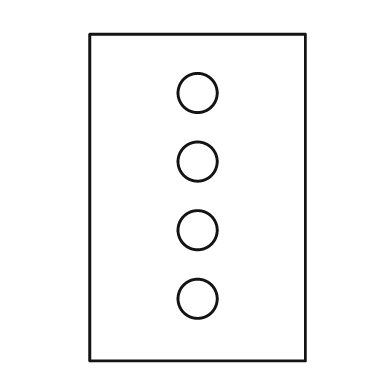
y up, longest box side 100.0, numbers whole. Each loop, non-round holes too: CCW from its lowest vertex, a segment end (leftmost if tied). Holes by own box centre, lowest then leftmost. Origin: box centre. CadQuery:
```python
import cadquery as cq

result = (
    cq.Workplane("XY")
    .moveTo(-33.0, -50.0)
    .lineTo(33.0, -50.0)
    .lineTo(33.0, 50.0)
    .lineTo(-33.0, 50.0)
    .close()
    .moveTo(0.0, -31.0)
    .circle(6.0)
    .moveTo(0.0, -10.0)
    .circle(6.0)
    .moveTo(0.0, 11.0)
    .circle(6.0)
    .moveTo(0.0, 32.0)
    .circle(6.0)
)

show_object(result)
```